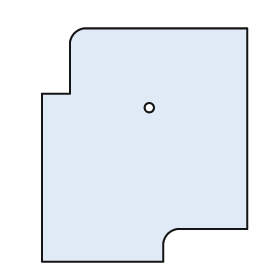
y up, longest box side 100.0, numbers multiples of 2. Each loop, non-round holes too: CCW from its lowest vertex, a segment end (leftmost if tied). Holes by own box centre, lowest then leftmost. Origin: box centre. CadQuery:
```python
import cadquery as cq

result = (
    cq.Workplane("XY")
    .moveTo(-44.0, -50.0)
    .lineTo(8.0, -50.0)
    .lineTo(8.0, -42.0)
    .threePointArc((10.0, -38.0), (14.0, -36.0))
    .lineTo(44.0, -36.0)
    .lineTo(44.0, 50.0)
    .lineTo(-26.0, 50.0)
    .threePointArc((-30.0, 48.0), (-32.0, 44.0))
    .lineTo(-32.0, 22.0)
    .lineTo(-44.0, 22.0)
    .close()
    .moveTo(2.0, 16.0)
    .circle(2.0)
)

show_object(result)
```